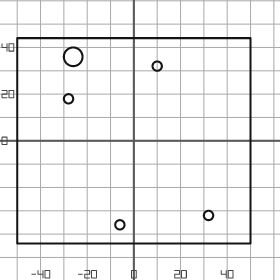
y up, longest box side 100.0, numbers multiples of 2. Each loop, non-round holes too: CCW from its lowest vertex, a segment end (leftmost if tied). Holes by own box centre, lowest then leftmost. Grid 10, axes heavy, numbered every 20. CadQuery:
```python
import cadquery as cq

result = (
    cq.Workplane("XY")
    .moveTo(-50.0, -44.0)
    .lineTo(50.0, -44.0)
    .lineTo(50.0, 44.0)
    .lineTo(-50.0, 44.0)
    .close()
    .moveTo(-6.0, -36.0)
    .circle(2.0)
    .moveTo(32.0, -32.0)
    .circle(2.0)
    .moveTo(-28.0, 18.0)
    .circle(2.0)
    .moveTo(10.0, 32.0)
    .circle(2.0)
    .moveTo(-26.0, 36.0)
    .circle(4.0)
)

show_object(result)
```